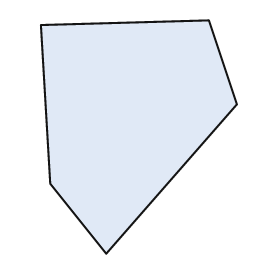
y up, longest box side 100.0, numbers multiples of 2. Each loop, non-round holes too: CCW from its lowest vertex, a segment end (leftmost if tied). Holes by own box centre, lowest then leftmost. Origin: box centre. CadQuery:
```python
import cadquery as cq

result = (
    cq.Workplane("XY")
    .moveTo(-14.0, -50.0)
    .lineTo(42.0, 14.0)
    .lineTo(30.0, 50.0)
    .lineTo(-42.0, 48.0)
    .lineTo(-38.0, -20.0)
    .close()
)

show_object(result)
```